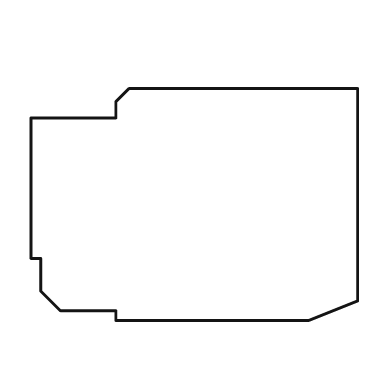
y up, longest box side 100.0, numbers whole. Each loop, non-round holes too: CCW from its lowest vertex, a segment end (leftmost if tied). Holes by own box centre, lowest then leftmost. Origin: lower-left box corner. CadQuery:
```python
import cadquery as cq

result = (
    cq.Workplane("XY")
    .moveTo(26.0, 0.0)
    .lineTo(85.0, 0.0)
    .lineTo(100.0, 6.0)
    .lineTo(100.0, 71.0)
    .lineTo(30.0, 71.0)
    .lineTo(26.0, 67.0)
    .lineTo(26.0, 62.0)
    .lineTo(0.0, 62.0)
    .lineTo(0.0, 19.0)
    .lineTo(3.0, 19.0)
    .lineTo(3.0, 9.0)
    .lineTo(9.0, 3.0)
    .lineTo(26.0, 3.0)
    .close()
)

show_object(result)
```